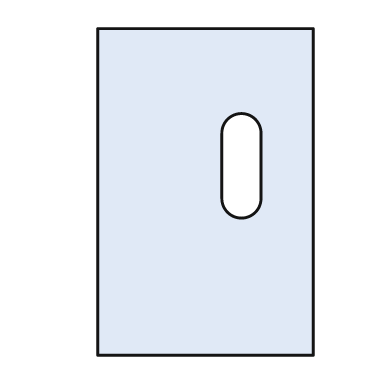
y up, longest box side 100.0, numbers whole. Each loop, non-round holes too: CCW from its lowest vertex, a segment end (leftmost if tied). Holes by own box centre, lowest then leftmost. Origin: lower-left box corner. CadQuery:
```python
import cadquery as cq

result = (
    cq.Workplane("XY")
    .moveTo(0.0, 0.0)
    .lineTo(66.0, 0.0)
    .lineTo(66.0, 100.0)
    .lineTo(0.0, 100.0)
    .close()
    .moveTo(38.0, 48.0)
    .threePointArc((44.0, 42.0), (50.0, 48.0))
    .lineTo(50.0, 68.0)
    .threePointArc((44.0, 74.0), (38.0, 68.0))
    .close()
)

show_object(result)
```